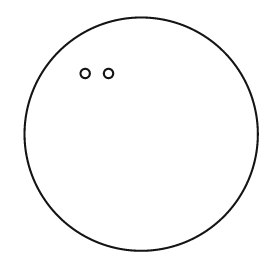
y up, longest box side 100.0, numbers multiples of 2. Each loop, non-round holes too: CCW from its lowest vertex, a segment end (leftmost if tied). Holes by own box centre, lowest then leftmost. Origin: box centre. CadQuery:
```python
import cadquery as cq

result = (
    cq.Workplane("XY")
    .moveTo(0.0, 0.0)
    .circle(50.0)
    .moveTo(-24.0, 26.0)
    .circle(2.0)
    .moveTo(-14.0, 26.0)
    .circle(2.0)
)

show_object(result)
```